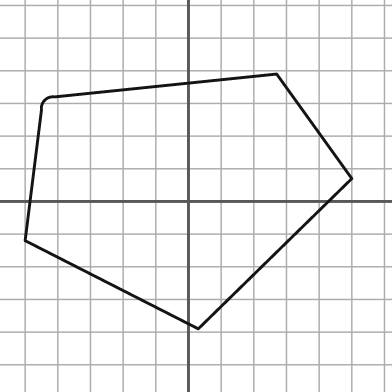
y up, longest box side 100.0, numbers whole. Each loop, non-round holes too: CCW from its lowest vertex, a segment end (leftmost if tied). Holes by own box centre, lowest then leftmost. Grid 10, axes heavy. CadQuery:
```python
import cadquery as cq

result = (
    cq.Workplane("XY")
    .moveTo(3.0, -39.0)
    .lineTo(50.0, 7.0)
    .lineTo(27.0, 39.0)
    .lineTo(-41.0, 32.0)
    .threePointArc((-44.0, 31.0), (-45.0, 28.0))
    .lineTo(-50.0, -12.0)
    .close()
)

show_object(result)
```